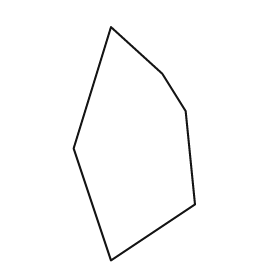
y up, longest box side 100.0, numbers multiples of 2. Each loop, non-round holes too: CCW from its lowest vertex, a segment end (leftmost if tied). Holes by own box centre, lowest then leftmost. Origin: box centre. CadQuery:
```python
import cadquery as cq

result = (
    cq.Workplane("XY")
    .moveTo(-10.0, -50.0)
    .lineTo(26.0, -26.0)
    .lineTo(22.0, 14.0)
    .lineTo(12.0, 30.0)
    .lineTo(-10.0, 50.0)
    .lineTo(-26.0, -2.0)
    .close()
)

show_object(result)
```